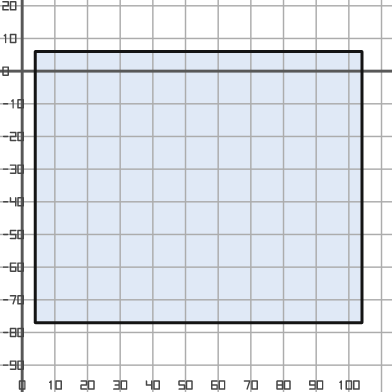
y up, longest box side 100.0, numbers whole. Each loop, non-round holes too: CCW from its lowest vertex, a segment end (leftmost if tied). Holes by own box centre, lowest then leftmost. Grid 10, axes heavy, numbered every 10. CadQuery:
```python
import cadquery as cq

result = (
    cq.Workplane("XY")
    .moveTo(4.0, -77.0)
    .lineTo(104.0, -77.0)
    .lineTo(104.0, 6.0)
    .lineTo(4.0, 6.0)
    .close()
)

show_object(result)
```